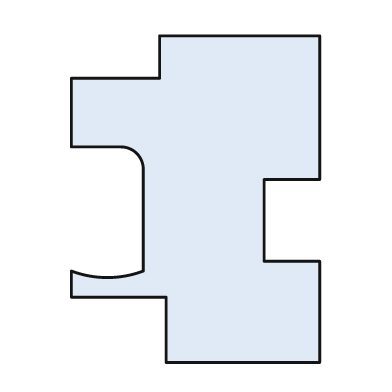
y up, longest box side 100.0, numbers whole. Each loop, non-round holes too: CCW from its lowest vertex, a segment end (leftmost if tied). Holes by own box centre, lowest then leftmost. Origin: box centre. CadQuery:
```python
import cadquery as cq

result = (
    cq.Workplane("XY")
    .moveTo(-9.0, -50.0)
    .lineTo(38.0, -50.0)
    .lineTo(38.0, -19.0)
    .lineTo(21.0, -19.0)
    .lineTo(21.0, 6.0)
    .lineTo(38.0, 6.0)
    .lineTo(38.0, 50.0)
    .lineTo(-11.0, 50.0)
    .lineTo(-11.0, 37.0)
    .lineTo(-38.0, 37.0)
    .lineTo(-38.0, 16.0)
    .lineTo(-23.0, 16.0)
    .threePointArc((-18.0, 14.0), (-16.0, 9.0))
    .lineTo(-16.0, -22.0)
    .threePointArc((-27.0, -24.0), (-38.0, -22.0))
    .lineTo(-38.0, -30.0)
    .lineTo(-9.0, -30.0)
    .close()
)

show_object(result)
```